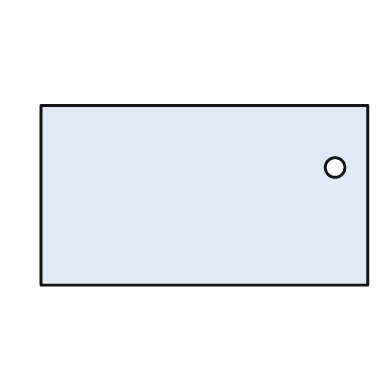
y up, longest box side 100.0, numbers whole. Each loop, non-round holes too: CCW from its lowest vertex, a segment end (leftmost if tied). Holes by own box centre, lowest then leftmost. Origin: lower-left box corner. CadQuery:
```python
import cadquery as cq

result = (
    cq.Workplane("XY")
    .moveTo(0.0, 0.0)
    .lineTo(100.0, 0.0)
    .lineTo(100.0, 55.0)
    .lineTo(0.0, 55.0)
    .close()
    .moveTo(90.0, 36.0)
    .circle(3.0)
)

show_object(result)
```